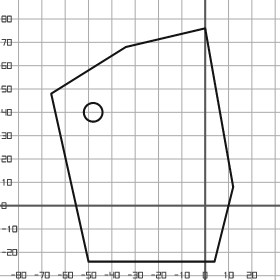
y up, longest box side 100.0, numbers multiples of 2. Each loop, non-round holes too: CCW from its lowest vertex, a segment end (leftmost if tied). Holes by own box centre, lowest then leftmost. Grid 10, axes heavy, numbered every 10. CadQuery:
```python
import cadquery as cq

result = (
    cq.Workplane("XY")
    .moveTo(-50.0, -24.0)
    .lineTo(4.0, -24.0)
    .lineTo(12.0, 8.0)
    .lineTo(0.0, 76.0)
    .lineTo(-34.0, 68.0)
    .lineTo(-66.0, 48.0)
    .close()
    .moveTo(-48.0, 40.0)
    .circle(4.0)
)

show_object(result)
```